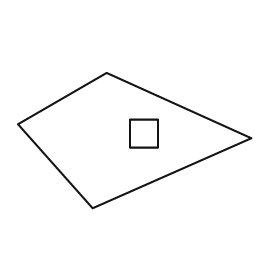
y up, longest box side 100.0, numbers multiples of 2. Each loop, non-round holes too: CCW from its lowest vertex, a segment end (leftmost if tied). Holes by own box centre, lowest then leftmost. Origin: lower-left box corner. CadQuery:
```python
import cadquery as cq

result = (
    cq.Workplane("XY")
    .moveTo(32.0, 0.0)
    .lineTo(100.0, 30.0)
    .lineTo(38.0, 58.0)
    .lineTo(0.0, 36.0)
    .close()
    .moveTo(48.0, 26.0)
    .lineTo(60.0, 26.0)
    .lineTo(60.0, 38.0)
    .lineTo(48.0, 38.0)
    .close()
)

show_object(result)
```